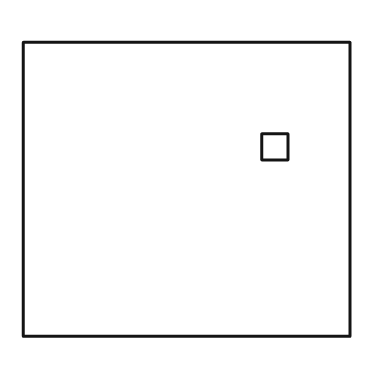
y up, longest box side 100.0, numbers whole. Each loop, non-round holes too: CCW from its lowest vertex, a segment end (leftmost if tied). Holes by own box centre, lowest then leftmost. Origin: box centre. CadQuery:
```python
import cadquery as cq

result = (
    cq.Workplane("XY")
    .moveTo(-50.0, -45.0)
    .lineTo(50.0, -45.0)
    .lineTo(50.0, 45.0)
    .lineTo(-50.0, 45.0)
    .close()
    .moveTo(23.0, 9.0)
    .lineTo(31.0, 9.0)
    .lineTo(31.0, 17.0)
    .lineTo(23.0, 17.0)
    .close()
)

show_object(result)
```